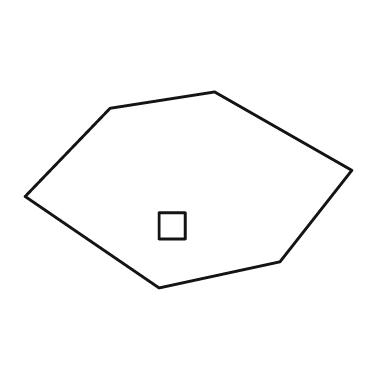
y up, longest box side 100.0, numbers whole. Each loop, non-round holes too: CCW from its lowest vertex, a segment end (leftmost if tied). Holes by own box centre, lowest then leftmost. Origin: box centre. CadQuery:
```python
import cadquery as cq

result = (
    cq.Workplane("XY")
    .moveTo(-9.0, -30.0)
    .lineTo(28.0, -22.0)
    .lineTo(50.0, 6.0)
    .lineTo(8.0, 30.0)
    .lineTo(-24.0, 25.0)
    .lineTo(-50.0, -2.0)
    .close()
    .moveTo(-9.0, -15.0)
    .lineTo(-1.0, -15.0)
    .lineTo(-1.0, -7.0)
    .lineTo(-9.0, -7.0)
    .close()
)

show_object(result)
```